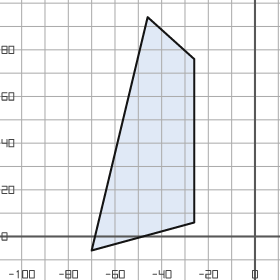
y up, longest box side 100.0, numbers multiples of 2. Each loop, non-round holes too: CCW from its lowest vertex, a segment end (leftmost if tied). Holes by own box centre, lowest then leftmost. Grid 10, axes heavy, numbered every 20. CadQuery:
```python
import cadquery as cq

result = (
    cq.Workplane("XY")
    .moveTo(-70.0, -6.0)
    .lineTo(-26.0, 6.0)
    .lineTo(-26.0, 76.0)
    .lineTo(-46.0, 94.0)
    .close()
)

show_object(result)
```